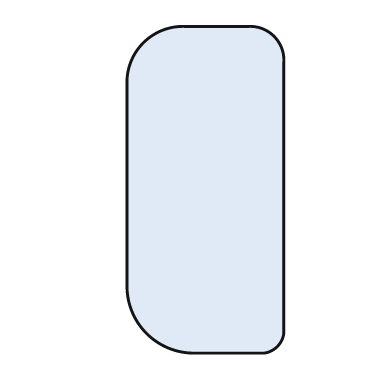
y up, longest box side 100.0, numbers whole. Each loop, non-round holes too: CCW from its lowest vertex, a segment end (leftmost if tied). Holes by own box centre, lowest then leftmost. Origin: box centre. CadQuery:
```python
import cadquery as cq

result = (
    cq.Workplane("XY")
    .moveTo(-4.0, -50.0)
    .lineTo(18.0, -50.0)
    .threePointArc((22.0, -48.0), (24.0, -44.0))
    .lineTo(24.0, 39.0)
    .threePointArc((21.0, 47.0), (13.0, 50.0))
    .lineTo(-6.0, 50.0)
    .threePointArc((-19.0, 45.0), (-24.0, 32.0))
    .lineTo(-24.0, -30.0)
    .threePointArc((-18.0, -44.0), (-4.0, -50.0))
    .close()
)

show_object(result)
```